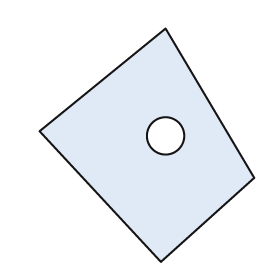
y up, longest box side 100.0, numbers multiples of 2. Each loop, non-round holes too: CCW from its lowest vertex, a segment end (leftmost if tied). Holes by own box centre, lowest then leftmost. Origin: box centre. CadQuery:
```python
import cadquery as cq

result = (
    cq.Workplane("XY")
    .moveTo(6.0, -50.0)
    .lineTo(46.0, -14.0)
    .lineTo(8.0, 50.0)
    .lineTo(-46.0, 6.0)
    .close()
    .moveTo(8.0, 4.0)
    .circle(8.0)
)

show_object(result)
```